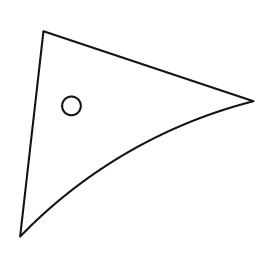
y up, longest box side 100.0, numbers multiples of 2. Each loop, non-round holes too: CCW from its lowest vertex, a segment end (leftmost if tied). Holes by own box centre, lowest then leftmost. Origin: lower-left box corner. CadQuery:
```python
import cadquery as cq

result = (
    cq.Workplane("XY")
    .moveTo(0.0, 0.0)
    .threePointArc((46.0, 36.0), (100.0, 58.0))
    .lineTo(10.0, 88.0)
    .close()
    .moveTo(22.0, 56.0)
    .circle(4.0)
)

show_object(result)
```